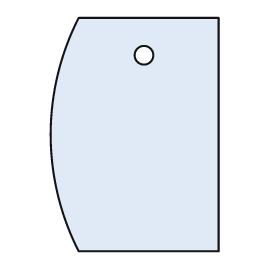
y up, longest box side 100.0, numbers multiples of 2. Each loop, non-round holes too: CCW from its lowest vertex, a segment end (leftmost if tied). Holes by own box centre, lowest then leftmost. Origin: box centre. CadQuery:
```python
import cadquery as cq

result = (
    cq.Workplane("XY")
    .moveTo(-24.0, -50.0)
    .lineTo(36.0, -50.0)
    .lineTo(36.0, 50.0)
    .lineTo(-24.0, 50.0)
    .threePointArc((-36.0, 0.0), (-24.0, -50.0))
    .close()
    .moveTo(4.0, 34.0)
    .circle(4.0)
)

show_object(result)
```